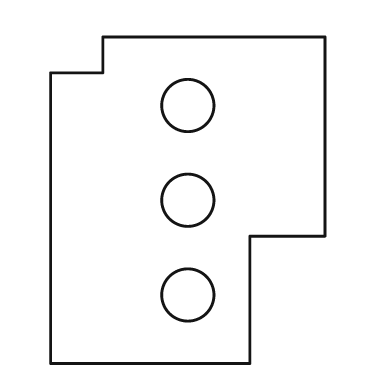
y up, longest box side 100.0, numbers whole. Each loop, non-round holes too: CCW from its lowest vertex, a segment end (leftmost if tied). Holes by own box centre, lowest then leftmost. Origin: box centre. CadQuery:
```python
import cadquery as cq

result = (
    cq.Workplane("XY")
    .moveTo(-42.0, -50.0)
    .lineTo(19.0, -50.0)
    .lineTo(19.0, -11.0)
    .lineTo(42.0, -11.0)
    .lineTo(42.0, 50.0)
    .lineTo(-26.0, 50.0)
    .lineTo(-26.0, 39.0)
    .lineTo(-42.0, 39.0)
    .close()
    .moveTo(0.0, -29.0)
    .circle(8.0)
    .moveTo(0.0, 0.0)
    .circle(8.0)
    .moveTo(0.0, 29.0)
    .circle(8.0)
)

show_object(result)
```